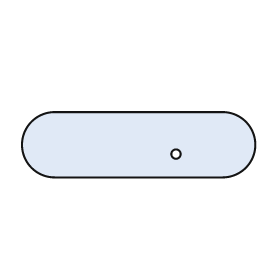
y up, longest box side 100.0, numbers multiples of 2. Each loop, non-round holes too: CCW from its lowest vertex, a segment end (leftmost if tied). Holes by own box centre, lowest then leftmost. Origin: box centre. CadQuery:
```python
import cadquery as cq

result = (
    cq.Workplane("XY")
    .moveTo(-36.0, -14.0)
    .lineTo(36.0, -14.0)
    .threePointArc((50.0, 0.0), (36.0, 14.0))
    .lineTo(-36.0, 14.0)
    .threePointArc((-50.0, 0.0), (-36.0, -14.0))
    .close()
    .moveTo(16.0, -4.0)
    .circle(2.0)
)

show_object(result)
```